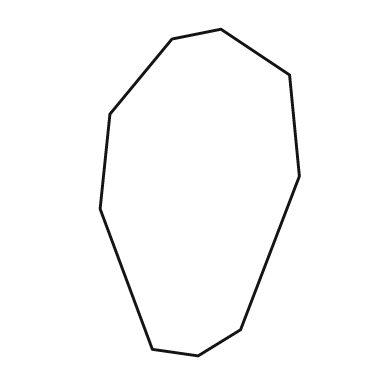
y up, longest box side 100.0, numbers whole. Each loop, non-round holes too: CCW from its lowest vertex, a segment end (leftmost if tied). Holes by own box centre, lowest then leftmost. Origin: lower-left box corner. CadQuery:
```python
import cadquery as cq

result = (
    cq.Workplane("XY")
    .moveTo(30.0, 0.0)
    .lineTo(43.0, 8.0)
    .lineTo(61.0, 55.0)
    .lineTo(58.0, 86.0)
    .lineTo(37.0, 100.0)
    .lineTo(22.0, 97.0)
    .lineTo(3.0, 74.0)
    .lineTo(0.0, 45.0)
    .lineTo(16.0, 2.0)
    .close()
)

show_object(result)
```